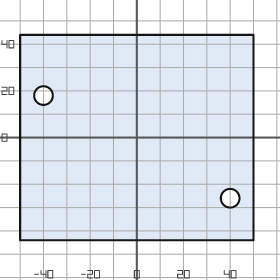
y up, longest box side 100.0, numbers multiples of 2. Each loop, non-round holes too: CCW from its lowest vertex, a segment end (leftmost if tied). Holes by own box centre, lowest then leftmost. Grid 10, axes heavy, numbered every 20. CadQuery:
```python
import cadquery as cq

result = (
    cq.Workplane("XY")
    .moveTo(-50.0, -44.0)
    .lineTo(50.0, -44.0)
    .lineTo(50.0, 44.0)
    .lineTo(-50.0, 44.0)
    .close()
    .moveTo(40.0, -26.0)
    .circle(4.0)
    .moveTo(-40.0, 18.0)
    .circle(4.0)
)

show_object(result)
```